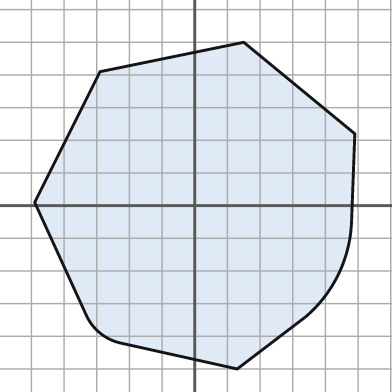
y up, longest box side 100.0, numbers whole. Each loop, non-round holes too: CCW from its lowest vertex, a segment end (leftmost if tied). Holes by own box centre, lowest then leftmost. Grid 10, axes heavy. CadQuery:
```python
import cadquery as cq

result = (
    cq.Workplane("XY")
    .moveTo(13.0, -50.0)
    .lineTo(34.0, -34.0)
    .threePointArc((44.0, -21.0), (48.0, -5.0))
    .lineTo(49.0, 22.0)
    .lineTo(15.0, 50.0)
    .lineTo(-29.0, 41.0)
    .lineTo(-49.0, 1.0)
    .lineTo(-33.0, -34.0)
    .threePointArc((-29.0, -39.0), (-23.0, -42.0))
    .close()
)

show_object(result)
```